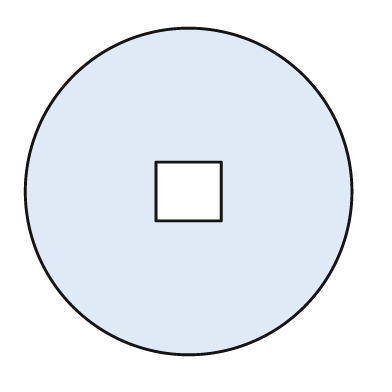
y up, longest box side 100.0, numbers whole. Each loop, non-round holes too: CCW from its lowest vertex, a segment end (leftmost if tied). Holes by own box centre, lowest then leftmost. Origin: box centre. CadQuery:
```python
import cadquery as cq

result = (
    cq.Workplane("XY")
    .moveTo(0.0, 0.0)
    .circle(50.0)
    .moveTo(-10.0, -9.0)
    .lineTo(10.0, -9.0)
    .lineTo(10.0, 9.0)
    .lineTo(-10.0, 9.0)
    .close()
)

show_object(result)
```